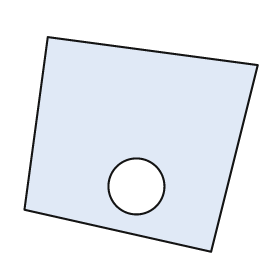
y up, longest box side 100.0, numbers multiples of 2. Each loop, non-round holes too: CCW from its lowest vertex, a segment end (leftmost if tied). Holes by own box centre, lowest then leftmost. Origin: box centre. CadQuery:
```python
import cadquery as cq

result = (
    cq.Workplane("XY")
    .moveTo(30.0, -46.0)
    .lineTo(50.0, 34.0)
    .lineTo(-40.0, 46.0)
    .lineTo(-50.0, -28.0)
    .close()
    .moveTo(-2.0, -18.0)
    .circle(12.0)
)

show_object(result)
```